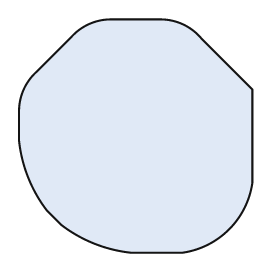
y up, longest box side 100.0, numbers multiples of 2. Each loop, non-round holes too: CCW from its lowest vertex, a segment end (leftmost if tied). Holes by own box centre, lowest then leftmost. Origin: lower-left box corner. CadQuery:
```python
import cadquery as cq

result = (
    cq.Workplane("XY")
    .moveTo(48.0, 0.0)
    .lineTo(70.0, 0.0)
    .threePointArc((90.0, 10.0), (100.0, 30.0))
    .lineTo(100.0, 70.0)
    .lineTo(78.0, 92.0)
    .threePointArc((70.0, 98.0), (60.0, 100.0))
    .lineTo(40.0, 100.0)
    .threePointArc((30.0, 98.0), (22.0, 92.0))
    .lineTo(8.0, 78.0)
    .threePointArc((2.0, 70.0), (0.0, 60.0))
    .lineTo(0.0, 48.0)
    .threePointArc((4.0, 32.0), (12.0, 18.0))
    .lineTo(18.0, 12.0)
    .threePointArc((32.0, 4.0), (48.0, 0.0))
    .close()
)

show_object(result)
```